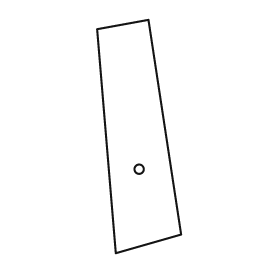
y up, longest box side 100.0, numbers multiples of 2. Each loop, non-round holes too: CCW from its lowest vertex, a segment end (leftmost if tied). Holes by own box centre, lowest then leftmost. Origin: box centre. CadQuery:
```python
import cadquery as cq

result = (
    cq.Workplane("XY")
    .moveTo(-10.0, -50.0)
    .lineTo(18.0, -42.0)
    .lineTo(4.0, 50.0)
    .lineTo(-18.0, 46.0)
    .close()
    .moveTo(0.0, -14.0)
    .circle(2.0)
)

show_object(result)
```